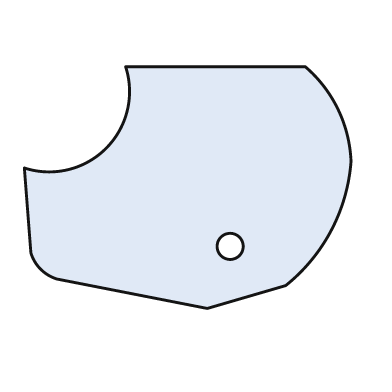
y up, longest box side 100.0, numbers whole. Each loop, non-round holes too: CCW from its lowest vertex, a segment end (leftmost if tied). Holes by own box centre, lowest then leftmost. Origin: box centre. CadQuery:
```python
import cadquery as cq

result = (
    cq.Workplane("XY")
    .moveTo(6.0, -37.0)
    .lineTo(30.0, -30.0)
    .threePointArc((44.0, -13.0), (50.0, 8.0))
    .threePointArc((46.0, 24.0), (36.0, 37.0))
    .lineTo(-19.0, 37.0)
    .threePointArc((-25.0, 12.0), (-50.0, 6.0))
    .lineTo(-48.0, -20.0)
    .threePointArc((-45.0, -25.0), (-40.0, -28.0))
    .close()
    .moveTo(13.0, -18.0)
    .circle(4.0)
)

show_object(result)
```